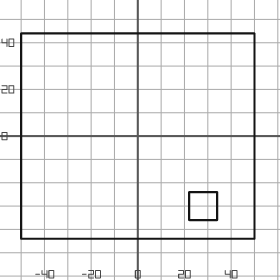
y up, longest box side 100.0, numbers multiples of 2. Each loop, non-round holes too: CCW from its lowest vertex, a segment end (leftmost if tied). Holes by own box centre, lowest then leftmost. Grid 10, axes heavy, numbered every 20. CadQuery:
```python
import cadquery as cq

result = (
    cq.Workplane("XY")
    .moveTo(-50.0, -44.0)
    .lineTo(50.0, -44.0)
    .lineTo(50.0, 44.0)
    .lineTo(-50.0, 44.0)
    .close()
    .moveTo(22.0, -36.0)
    .lineTo(34.0, -36.0)
    .lineTo(34.0, -24.0)
    .lineTo(22.0, -24.0)
    .close()
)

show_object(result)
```